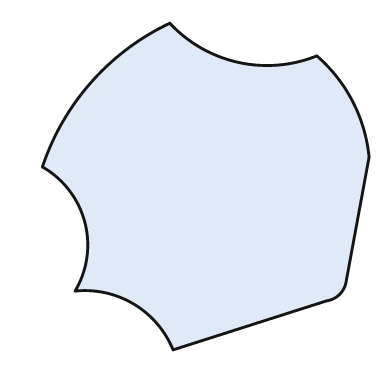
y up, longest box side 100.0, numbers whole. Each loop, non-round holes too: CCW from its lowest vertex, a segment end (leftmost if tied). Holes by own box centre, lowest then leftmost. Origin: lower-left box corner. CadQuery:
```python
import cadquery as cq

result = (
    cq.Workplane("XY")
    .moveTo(40.0, 0.0)
    .lineTo(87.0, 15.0)
    .threePointArc((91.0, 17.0), (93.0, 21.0))
    .lineTo(100.0, 59.0)
    .threePointArc((95.0, 76.0), (84.0, 90.0))
    .threePointArc((60.0, 88.0), (39.0, 100.0))
    .threePointArc((15.0, 82.0), (0.0, 56.0))
    .threePointArc((13.0, 39.0), (10.0, 18.0))
    .threePointArc((28.0, 14.0), (40.0, 0.0))
    .close()
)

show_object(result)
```